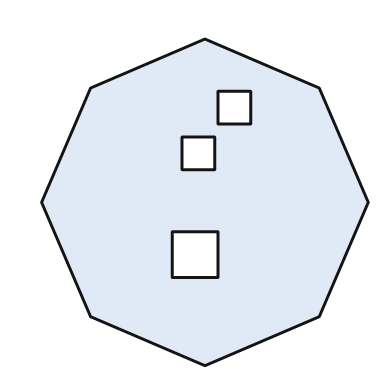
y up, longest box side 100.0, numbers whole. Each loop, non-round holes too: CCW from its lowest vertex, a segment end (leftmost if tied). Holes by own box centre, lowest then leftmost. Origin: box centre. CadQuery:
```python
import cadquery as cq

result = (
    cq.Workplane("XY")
    .moveTo(0.0, -50.0)
    .lineTo(35.0, -35.0)
    .lineTo(50.0, 0.0)
    .lineTo(35.0, 35.0)
    .lineTo(0.0, 50.0)
    .lineTo(-35.0, 35.0)
    .lineTo(-50.0, 0.0)
    .lineTo(-35.0, -35.0)
    .close()
    .moveTo(-10.0, -23.0)
    .lineTo(4.0, -23.0)
    .lineTo(4.0, -9.0)
    .lineTo(-10.0, -9.0)
    .close()
    .moveTo(-7.0, 10.0)
    .lineTo(3.0, 10.0)
    .lineTo(3.0, 20.0)
    .lineTo(-7.0, 20.0)
    .close()
    .moveTo(4.0, 24.0)
    .lineTo(14.0, 24.0)
    .lineTo(14.0, 34.0)
    .lineTo(4.0, 34.0)
    .close()
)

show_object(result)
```